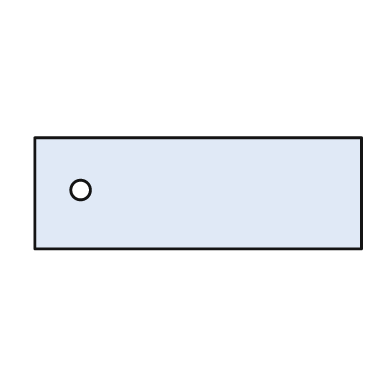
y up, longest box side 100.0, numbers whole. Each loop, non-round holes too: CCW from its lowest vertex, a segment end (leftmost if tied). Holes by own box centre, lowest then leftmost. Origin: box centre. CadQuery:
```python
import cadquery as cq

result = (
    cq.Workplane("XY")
    .moveTo(-50.0, -17.0)
    .lineTo(50.0, -17.0)
    .lineTo(50.0, 17.0)
    .lineTo(-50.0, 17.0)
    .close()
    .moveTo(-36.0, 1.0)
    .circle(3.0)
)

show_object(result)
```